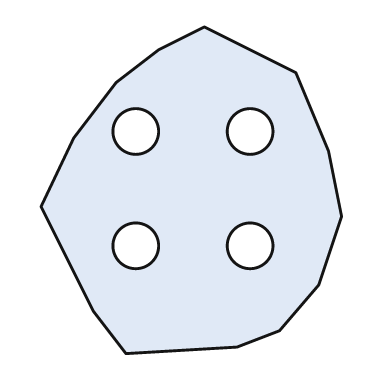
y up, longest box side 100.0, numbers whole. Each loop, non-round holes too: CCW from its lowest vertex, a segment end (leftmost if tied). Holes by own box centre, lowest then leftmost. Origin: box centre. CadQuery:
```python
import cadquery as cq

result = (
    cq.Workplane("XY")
    .moveTo(-20.0, -50.0)
    .lineTo(14.0, -48.0)
    .lineTo(27.0, -43.0)
    .lineTo(39.0, -29.0)
    .lineTo(46.0, -8.0)
    .lineTo(42.0, 12.0)
    .lineTo(32.0, 36.0)
    .lineTo(4.0, 50.0)
    .lineTo(-10.0, 43.0)
    .lineTo(-23.0, 33.0)
    .lineTo(-36.0, 16.0)
    .lineTo(-46.0, -5.0)
    .lineTo(-30.0, -37.0)
    .close()
    .moveTo(-17.0, -17.0)
    .circle(7.0)
    .moveTo(18.0, -17.0)
    .circle(7.0)
    .moveTo(-17.0, 18.0)
    .circle(7.0)
    .moveTo(18.0, 18.0)
    .circle(7.0)
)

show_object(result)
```